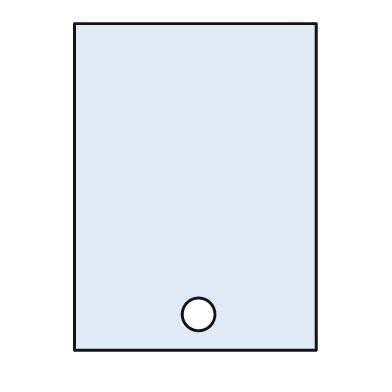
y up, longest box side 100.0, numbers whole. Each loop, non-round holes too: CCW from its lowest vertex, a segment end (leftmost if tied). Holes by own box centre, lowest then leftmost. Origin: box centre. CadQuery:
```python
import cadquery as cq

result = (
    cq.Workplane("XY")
    .moveTo(-37.0, -50.0)
    .lineTo(37.0, -50.0)
    .lineTo(37.0, 50.0)
    .lineTo(-37.0, 50.0)
    .close()
    .moveTo(1.0, -39.0)
    .circle(5.0)
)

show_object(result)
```